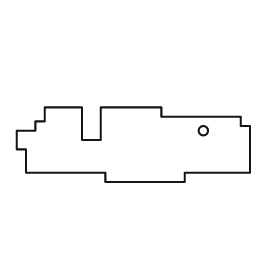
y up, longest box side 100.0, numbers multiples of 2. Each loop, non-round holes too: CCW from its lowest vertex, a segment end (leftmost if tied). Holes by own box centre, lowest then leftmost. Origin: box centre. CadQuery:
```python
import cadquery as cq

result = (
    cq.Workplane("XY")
    .moveTo(-12.0, -16.0)
    .lineTo(22.0, -16.0)
    .lineTo(22.0, -12.0)
    .lineTo(50.0, -12.0)
    .lineTo(50.0, 8.0)
    .lineTo(46.0, 8.0)
    .lineTo(46.0, 12.0)
    .lineTo(12.0, 12.0)
    .lineTo(12.0, 16.0)
    .lineTo(-14.0, 16.0)
    .lineTo(-14.0, 2.0)
    .lineTo(-22.0, 2.0)
    .lineTo(-22.0, 16.0)
    .lineTo(-38.0, 16.0)
    .lineTo(-38.0, 10.0)
    .lineTo(-42.0, 10.0)
    .lineTo(-42.0, 6.0)
    .lineTo(-50.0, 6.0)
    .lineTo(-50.0, -2.0)
    .lineTo(-46.0, -2.0)
    .lineTo(-46.0, -12.0)
    .lineTo(-12.0, -12.0)
    .close()
    .moveTo(30.0, 6.0)
    .circle(2.0)
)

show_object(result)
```